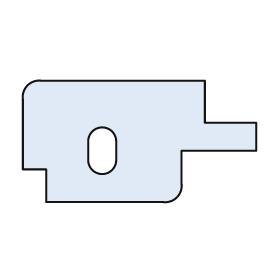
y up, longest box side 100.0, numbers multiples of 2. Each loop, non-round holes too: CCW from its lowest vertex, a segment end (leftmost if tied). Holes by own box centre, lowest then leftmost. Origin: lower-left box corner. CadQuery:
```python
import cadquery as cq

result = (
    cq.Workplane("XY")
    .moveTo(10.0, 0.0)
    .lineTo(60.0, 0.0)
    .threePointArc((66.0, 2.0), (68.0, 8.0))
    .lineTo(68.0, 22.0)
    .lineTo(100.0, 22.0)
    .lineTo(100.0, 34.0)
    .lineTo(78.0, 34.0)
    .lineTo(78.0, 52.0)
    .lineTo(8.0, 52.0)
    .threePointArc((2.0, 50.0), (0.0, 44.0))
    .lineTo(0.0, 14.0)
    .lineTo(10.0, 14.0)
    .close()
    .moveTo(28.0, 18.0)
    .threePointArc((34.0, 12.0), (40.0, 18.0))
    .lineTo(40.0, 26.0)
    .threePointArc((34.0, 32.0), (28.0, 26.0))
    .close()
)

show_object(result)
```